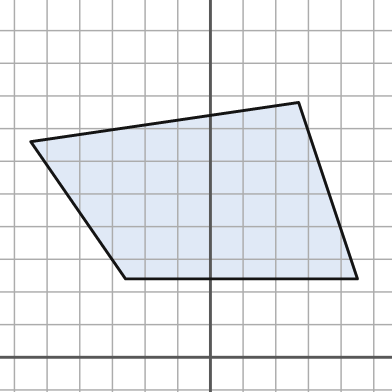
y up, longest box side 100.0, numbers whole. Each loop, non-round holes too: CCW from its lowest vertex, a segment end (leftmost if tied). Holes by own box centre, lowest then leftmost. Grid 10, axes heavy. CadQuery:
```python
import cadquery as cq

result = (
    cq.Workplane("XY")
    .moveTo(-26.0, 24.0)
    .lineTo(45.0, 24.0)
    .lineTo(27.0, 78.0)
    .lineTo(-55.0, 66.0)
    .close()
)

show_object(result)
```